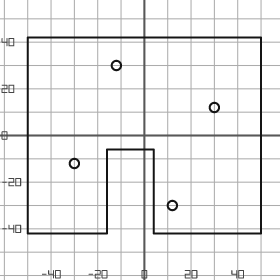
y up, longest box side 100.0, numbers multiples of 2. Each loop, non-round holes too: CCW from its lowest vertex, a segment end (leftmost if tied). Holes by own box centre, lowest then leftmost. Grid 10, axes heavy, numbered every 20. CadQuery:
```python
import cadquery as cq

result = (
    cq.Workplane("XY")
    .moveTo(-50.0, -42.0)
    .lineTo(-16.0, -42.0)
    .lineTo(-16.0, -6.0)
    .lineTo(4.0, -6.0)
    .lineTo(4.0, -42.0)
    .lineTo(50.0, -42.0)
    .lineTo(50.0, 42.0)
    .lineTo(-50.0, 42.0)
    .close()
    .moveTo(12.0, -30.0)
    .circle(2.0)
    .moveTo(-30.0, -12.0)
    .circle(2.0)
    .moveTo(30.0, 12.0)
    .circle(2.0)
    .moveTo(-12.0, 30.0)
    .circle(2.0)
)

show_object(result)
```